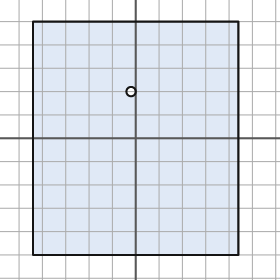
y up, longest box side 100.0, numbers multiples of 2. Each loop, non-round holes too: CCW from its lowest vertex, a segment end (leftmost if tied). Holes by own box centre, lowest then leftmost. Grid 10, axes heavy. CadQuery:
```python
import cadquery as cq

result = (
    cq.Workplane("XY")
    .moveTo(-44.0, -50.0)
    .lineTo(44.0, -50.0)
    .lineTo(44.0, 50.0)
    .lineTo(-44.0, 50.0)
    .close()
    .moveTo(-2.0, 20.0)
    .circle(2.0)
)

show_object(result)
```